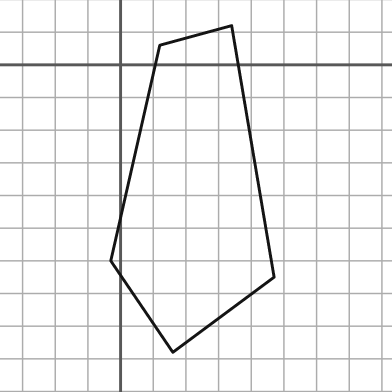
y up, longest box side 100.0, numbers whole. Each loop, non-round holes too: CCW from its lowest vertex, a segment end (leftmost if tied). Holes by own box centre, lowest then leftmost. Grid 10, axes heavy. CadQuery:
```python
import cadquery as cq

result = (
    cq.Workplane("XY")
    .moveTo(16.0, -88.0)
    .lineTo(47.0, -65.0)
    .lineTo(34.0, 12.0)
    .lineTo(12.0, 6.0)
    .lineTo(-3.0, -60.0)
    .close()
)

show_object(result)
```